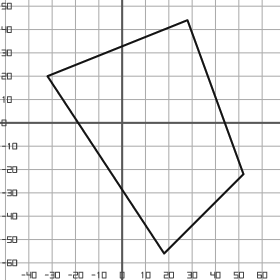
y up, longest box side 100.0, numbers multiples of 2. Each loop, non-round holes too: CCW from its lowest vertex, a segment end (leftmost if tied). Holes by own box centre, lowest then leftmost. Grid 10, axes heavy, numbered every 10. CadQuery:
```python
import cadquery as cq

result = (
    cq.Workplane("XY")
    .moveTo(18.0, -56.0)
    .lineTo(52.0, -22.0)
    .lineTo(28.0, 44.0)
    .lineTo(-32.0, 20.0)
    .close()
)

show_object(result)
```